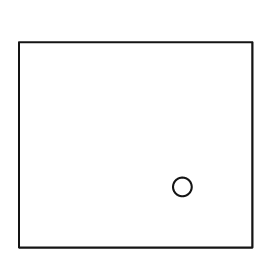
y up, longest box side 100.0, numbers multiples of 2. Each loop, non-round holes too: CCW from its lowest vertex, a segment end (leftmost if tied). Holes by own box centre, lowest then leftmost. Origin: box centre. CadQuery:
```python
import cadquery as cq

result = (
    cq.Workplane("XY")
    .moveTo(-50.0, -44.0)
    .lineTo(50.0, -44.0)
    .lineTo(50.0, 44.0)
    .lineTo(-50.0, 44.0)
    .close()
    .moveTo(20.0, -18.0)
    .circle(4.0)
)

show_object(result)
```